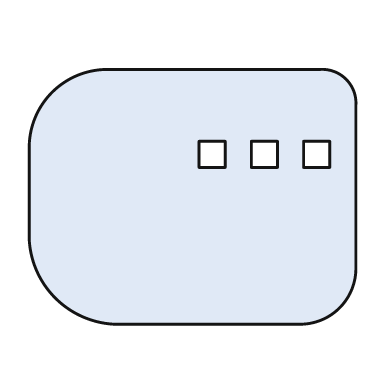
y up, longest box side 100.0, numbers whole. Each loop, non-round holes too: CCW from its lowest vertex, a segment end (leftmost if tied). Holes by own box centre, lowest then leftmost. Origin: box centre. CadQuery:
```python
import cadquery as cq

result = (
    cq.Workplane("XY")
    .moveTo(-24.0, -39.0)
    .lineTo(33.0, -39.0)
    .threePointArc((45.0, -34.0), (50.0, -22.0))
    .lineTo(50.0, 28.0)
    .threePointArc((47.0, 36.0), (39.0, 39.0))
    .lineTo(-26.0, 39.0)
    .threePointArc((-43.0, 32.0), (-50.0, 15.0))
    .lineTo(-50.0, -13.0)
    .threePointArc((-42.0, -31.0), (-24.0, -39.0))
    .close()
    .moveTo(2.0, 9.0)
    .lineTo(10.0, 9.0)
    .lineTo(10.0, 17.0)
    .lineTo(2.0, 17.0)
    .close()
    .moveTo(18.0, 9.0)
    .lineTo(26.0, 9.0)
    .lineTo(26.0, 17.0)
    .lineTo(18.0, 17.0)
    .close()
    .moveTo(34.0, 9.0)
    .lineTo(42.0, 9.0)
    .lineTo(42.0, 17.0)
    .lineTo(34.0, 17.0)
    .close()
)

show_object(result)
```